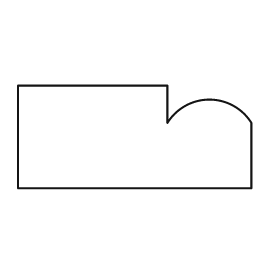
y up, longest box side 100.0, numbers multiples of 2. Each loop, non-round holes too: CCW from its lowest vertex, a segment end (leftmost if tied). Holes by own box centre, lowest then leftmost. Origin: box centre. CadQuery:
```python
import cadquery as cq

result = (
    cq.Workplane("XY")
    .moveTo(-50.0, -22.0)
    .lineTo(50.0, -22.0)
    .lineTo(50.0, 6.0)
    .threePointArc((32.0, 16.0), (14.0, 6.0))
    .lineTo(14.0, 22.0)
    .lineTo(-50.0, 22.0)
    .close()
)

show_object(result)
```